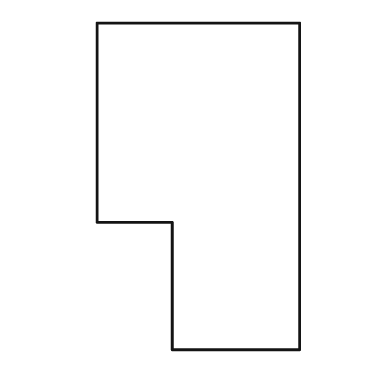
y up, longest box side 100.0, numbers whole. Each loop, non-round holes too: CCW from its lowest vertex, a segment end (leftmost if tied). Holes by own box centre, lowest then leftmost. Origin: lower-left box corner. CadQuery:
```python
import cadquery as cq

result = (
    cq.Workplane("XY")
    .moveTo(23.0, 0.0)
    .lineTo(62.0, 0.0)
    .lineTo(62.0, 100.0)
    .lineTo(0.0, 100.0)
    .lineTo(0.0, 39.0)
    .lineTo(23.0, 39.0)
    .close()
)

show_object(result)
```